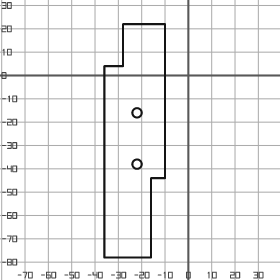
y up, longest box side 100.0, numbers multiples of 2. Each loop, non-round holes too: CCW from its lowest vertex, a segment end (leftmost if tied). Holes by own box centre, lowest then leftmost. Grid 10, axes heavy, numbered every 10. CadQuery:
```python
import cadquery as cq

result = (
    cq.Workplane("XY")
    .moveTo(-36.0, -78.0)
    .lineTo(-16.0, -78.0)
    .lineTo(-16.0, -44.0)
    .lineTo(-10.0, -44.0)
    .lineTo(-10.0, 22.0)
    .lineTo(-28.0, 22.0)
    .lineTo(-28.0, 4.0)
    .lineTo(-36.0, 4.0)
    .close()
    .moveTo(-22.0, -38.0)
    .circle(2.0)
    .moveTo(-22.0, -16.0)
    .circle(2.0)
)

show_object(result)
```